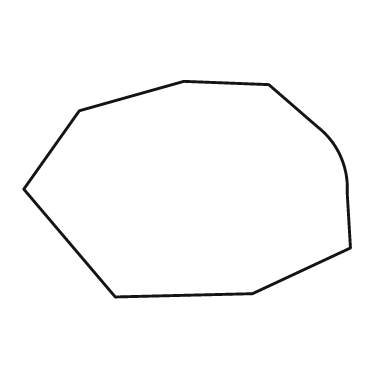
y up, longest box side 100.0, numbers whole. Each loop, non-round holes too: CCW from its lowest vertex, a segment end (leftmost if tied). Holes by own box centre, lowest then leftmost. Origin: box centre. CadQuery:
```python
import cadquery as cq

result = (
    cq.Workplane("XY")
    .moveTo(-22.0, -33.0)
    .lineTo(20.0, -32.0)
    .lineTo(50.0, -18.0)
    .lineTo(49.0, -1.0)
    .threePointArc((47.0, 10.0), (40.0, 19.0))
    .lineTo(25.0, 32.0)
    .lineTo(-1.0, 33.0)
    .lineTo(-33.0, 24.0)
    .lineTo(-50.0, 0.0)
    .close()
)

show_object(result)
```